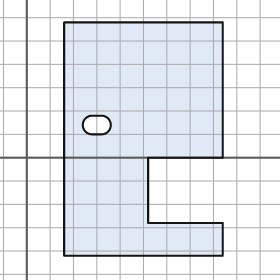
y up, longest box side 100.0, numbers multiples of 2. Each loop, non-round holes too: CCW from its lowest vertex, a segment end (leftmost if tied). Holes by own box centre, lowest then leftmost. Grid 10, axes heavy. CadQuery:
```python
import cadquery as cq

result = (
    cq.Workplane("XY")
    .moveTo(16.0, -42.0)
    .lineTo(84.0, -42.0)
    .lineTo(84.0, -28.0)
    .lineTo(52.0, -28.0)
    .lineTo(52.0, 0.0)
    .lineTo(84.0, 0.0)
    .lineTo(84.0, 58.0)
    .lineTo(16.0, 58.0)
    .close()
    .moveTo(28.0, 10.0)
    .lineTo(32.0, 10.0)
    .threePointArc((36.0, 14.0), (32.0, 18.0))
    .lineTo(28.0, 18.0)
    .threePointArc((24.0, 14.0), (28.0, 10.0))
    .close()
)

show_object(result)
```